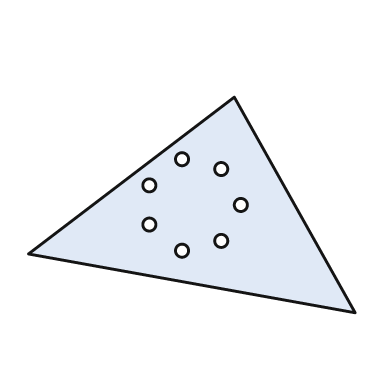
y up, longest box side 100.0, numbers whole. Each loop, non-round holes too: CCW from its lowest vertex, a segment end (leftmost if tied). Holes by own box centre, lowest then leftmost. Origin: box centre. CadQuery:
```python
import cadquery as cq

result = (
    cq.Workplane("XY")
    .moveTo(50.0, -33.0)
    .lineTo(13.0, 33.0)
    .lineTo(-50.0, -15.0)
    .close()
    .moveTo(-3.0, -14.0)
    .circle(2.0)
    .moveTo(9.0, -11.0)
    .circle(2.0)
    .moveTo(-13.0, -6.0)
    .circle(2.0)
    .moveTo(15.0, 0.0)
    .circle(2.0)
    .moveTo(-13.0, 6.0)
    .circle(2.0)
    .moveTo(9.0, 11.0)
    .circle(2.0)
    .moveTo(-3.0, 14.0)
    .circle(2.0)
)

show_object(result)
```